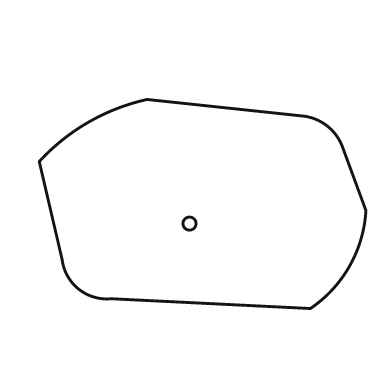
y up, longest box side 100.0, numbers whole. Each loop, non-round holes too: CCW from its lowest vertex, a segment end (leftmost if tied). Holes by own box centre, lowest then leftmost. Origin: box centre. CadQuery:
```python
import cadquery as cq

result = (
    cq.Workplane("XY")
    .moveTo(33.0, -32.0)
    .threePointArc((45.0, -19.0), (50.0, -2.0))
    .lineTo(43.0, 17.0)
    .threePointArc((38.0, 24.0), (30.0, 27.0))
    .lineTo(-17.0, 32.0)
    .threePointArc((-35.0, 25.0), (-50.0, 13.0))
    .lineTo(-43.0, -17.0)
    .threePointArc((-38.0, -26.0), (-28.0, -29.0))
    .close()
    .moveTo(-4.0, -6.0)
    .circle(2.0)
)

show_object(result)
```